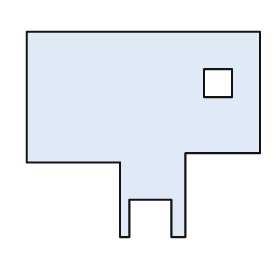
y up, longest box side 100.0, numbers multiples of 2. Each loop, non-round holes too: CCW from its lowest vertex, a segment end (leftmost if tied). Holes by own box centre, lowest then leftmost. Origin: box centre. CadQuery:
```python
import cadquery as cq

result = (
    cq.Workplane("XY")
    .moveTo(-10.0, -44.0)
    .lineTo(-6.0, -44.0)
    .lineTo(-6.0, -28.0)
    .lineTo(12.0, -28.0)
    .lineTo(12.0, -44.0)
    .lineTo(18.0, -44.0)
    .lineTo(18.0, -8.0)
    .lineTo(50.0, -8.0)
    .lineTo(50.0, 44.0)
    .lineTo(-50.0, 44.0)
    .lineTo(-50.0, -12.0)
    .lineTo(-10.0, -12.0)
    .close()
    .moveTo(26.0, 16.0)
    .lineTo(38.0, 16.0)
    .lineTo(38.0, 28.0)
    .lineTo(26.0, 28.0)
    .close()
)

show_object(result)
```